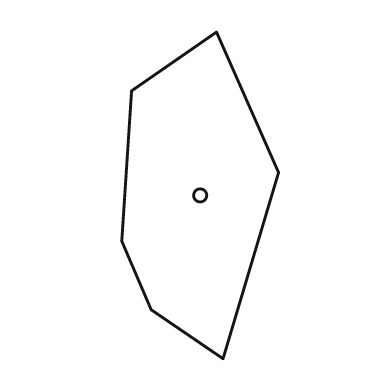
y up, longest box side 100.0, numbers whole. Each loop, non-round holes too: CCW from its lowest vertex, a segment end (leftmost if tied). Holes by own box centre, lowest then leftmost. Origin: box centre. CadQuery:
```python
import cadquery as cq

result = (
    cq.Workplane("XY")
    .moveTo(7.0, -50.0)
    .lineTo(24.0, 7.0)
    .lineTo(5.0, 50.0)
    .lineTo(-21.0, 32.0)
    .lineTo(-24.0, -14.0)
    .lineTo(-15.0, -35.0)
    .close()
    .moveTo(0.0, 0.0)
    .circle(2.0)
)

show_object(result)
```